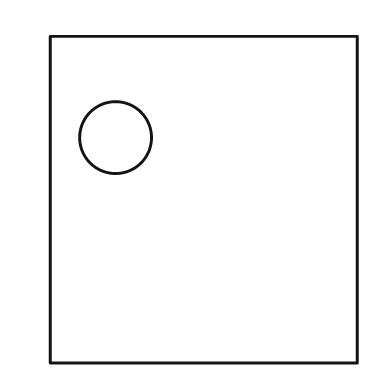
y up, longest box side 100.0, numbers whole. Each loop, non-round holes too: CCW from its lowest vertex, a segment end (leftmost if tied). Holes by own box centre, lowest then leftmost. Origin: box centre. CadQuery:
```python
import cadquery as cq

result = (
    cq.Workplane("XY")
    .moveTo(-47.0, -50.0)
    .lineTo(47.0, -50.0)
    .lineTo(47.0, 50.0)
    .lineTo(-47.0, 50.0)
    .close()
    .moveTo(-27.0, 19.0)
    .circle(11.0)
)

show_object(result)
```